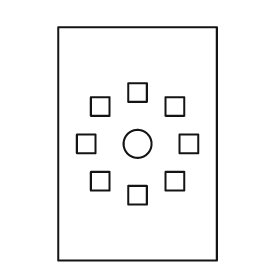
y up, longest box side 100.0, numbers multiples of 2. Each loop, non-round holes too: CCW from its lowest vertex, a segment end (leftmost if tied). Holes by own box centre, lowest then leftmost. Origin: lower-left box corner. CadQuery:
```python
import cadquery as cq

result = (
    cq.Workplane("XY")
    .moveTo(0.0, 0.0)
    .lineTo(68.0, 0.0)
    .lineTo(68.0, 100.0)
    .lineTo(0.0, 100.0)
    .close()
    .moveTo(30.0, 24.0)
    .lineTo(38.0, 24.0)
    .lineTo(38.0, 32.0)
    .lineTo(30.0, 32.0)
    .close()
    .moveTo(14.0, 30.0)
    .lineTo(22.0, 30.0)
    .lineTo(22.0, 38.0)
    .lineTo(14.0, 38.0)
    .close()
    .moveTo(46.0, 30.0)
    .lineTo(54.0, 30.0)
    .lineTo(54.0, 38.0)
    .lineTo(46.0, 38.0)
    .close()
    .moveTo(8.0, 46.0)
    .lineTo(16.0, 46.0)
    .lineTo(16.0, 54.0)
    .lineTo(8.0, 54.0)
    .close()
    .moveTo(34.0, 50.0)
    .circle(6.0)
    .moveTo(52.0, 46.0)
    .lineTo(60.0, 46.0)
    .lineTo(60.0, 54.0)
    .lineTo(52.0, 54.0)
    .close()
    .moveTo(14.0, 62.0)
    .lineTo(22.0, 62.0)
    .lineTo(22.0, 70.0)
    .lineTo(14.0, 70.0)
    .close()
    .moveTo(46.0, 62.0)
    .lineTo(54.0, 62.0)
    .lineTo(54.0, 70.0)
    .lineTo(46.0, 70.0)
    .close()
    .moveTo(30.0, 68.0)
    .lineTo(38.0, 68.0)
    .lineTo(38.0, 76.0)
    .lineTo(30.0, 76.0)
    .close()
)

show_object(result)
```